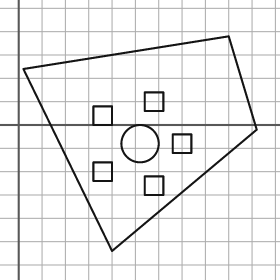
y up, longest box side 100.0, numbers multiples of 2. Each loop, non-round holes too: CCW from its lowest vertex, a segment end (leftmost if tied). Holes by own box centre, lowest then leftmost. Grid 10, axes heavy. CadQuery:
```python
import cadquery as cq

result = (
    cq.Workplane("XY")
    .moveTo(40.0, -54.0)
    .lineTo(102.0, -2.0)
    .lineTo(90.0, 38.0)
    .lineTo(2.0, 24.0)
    .close()
    .moveTo(54.0, -30.0)
    .lineTo(62.0, -30.0)
    .lineTo(62.0, -22.0)
    .lineTo(54.0, -22.0)
    .close()
    .moveTo(32.0, -24.0)
    .lineTo(40.0, -24.0)
    .lineTo(40.0, -16.0)
    .lineTo(32.0, -16.0)
    .close()
    .moveTo(52.0, -8.0)
    .circle(8.0)
    .moveTo(66.0, -12.0)
    .lineTo(74.0, -12.0)
    .lineTo(74.0, -4.0)
    .lineTo(66.0, -4.0)
    .close()
    .moveTo(32.0, 0.0)
    .lineTo(40.0, 0.0)
    .lineTo(40.0, 8.0)
    .lineTo(32.0, 8.0)
    .close()
    .moveTo(54.0, 6.0)
    .lineTo(62.0, 6.0)
    .lineTo(62.0, 14.0)
    .lineTo(54.0, 14.0)
    .close()
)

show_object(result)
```